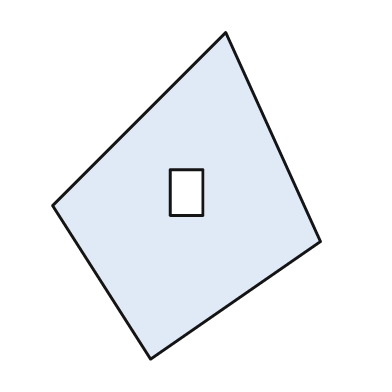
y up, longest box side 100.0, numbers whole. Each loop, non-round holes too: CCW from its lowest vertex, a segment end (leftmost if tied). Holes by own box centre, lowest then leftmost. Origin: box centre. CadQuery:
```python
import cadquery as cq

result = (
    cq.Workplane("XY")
    .moveTo(-11.0, -50.0)
    .lineTo(41.0, -14.0)
    .lineTo(12.0, 50.0)
    .lineTo(-41.0, -3.0)
    .close()
    .moveTo(-5.0, -6.0)
    .lineTo(5.0, -6.0)
    .lineTo(5.0, 8.0)
    .lineTo(-5.0, 8.0)
    .close()
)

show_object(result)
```